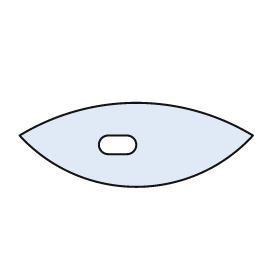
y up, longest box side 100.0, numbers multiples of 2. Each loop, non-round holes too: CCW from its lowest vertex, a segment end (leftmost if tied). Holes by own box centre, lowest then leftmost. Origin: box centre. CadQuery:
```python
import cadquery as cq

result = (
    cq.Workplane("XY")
    .moveTo(-50.0, 4.0)
    .threePointArc((0.0, -18.0), (50.0, 4.0))
    .threePointArc((0.0, 18.0), (-50.0, 4.0))
    .close()
    .moveTo(-12.0, -4.0)
    .lineTo(-4.0, -4.0)
    .threePointArc((0.0, 0.0), (-4.0, 4.0))
    .lineTo(-12.0, 4.0)
    .threePointArc((-16.0, 0.0), (-12.0, -4.0))
    .close()
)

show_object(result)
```